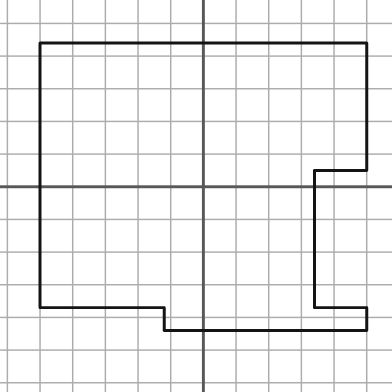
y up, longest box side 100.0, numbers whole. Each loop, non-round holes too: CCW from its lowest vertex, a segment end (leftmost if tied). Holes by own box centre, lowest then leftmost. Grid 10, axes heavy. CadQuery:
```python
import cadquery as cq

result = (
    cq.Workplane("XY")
    .moveTo(-12.0, -44.0)
    .lineTo(50.0, -44.0)
    .lineTo(50.0, -37.0)
    .lineTo(34.0, -37.0)
    .lineTo(34.0, 5.0)
    .lineTo(50.0, 5.0)
    .lineTo(50.0, 44.0)
    .lineTo(-50.0, 44.0)
    .lineTo(-50.0, -37.0)
    .lineTo(-12.0, -37.0)
    .close()
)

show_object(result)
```